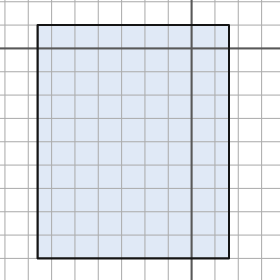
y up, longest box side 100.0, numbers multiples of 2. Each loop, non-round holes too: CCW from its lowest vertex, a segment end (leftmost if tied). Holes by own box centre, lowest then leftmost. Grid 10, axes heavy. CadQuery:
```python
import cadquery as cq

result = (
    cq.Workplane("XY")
    .moveTo(-66.0, -90.0)
    .lineTo(16.0, -90.0)
    .lineTo(16.0, 10.0)
    .lineTo(-66.0, 10.0)
    .close()
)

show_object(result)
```